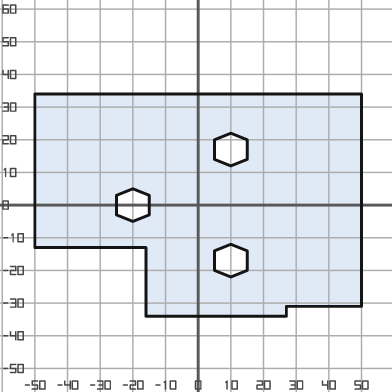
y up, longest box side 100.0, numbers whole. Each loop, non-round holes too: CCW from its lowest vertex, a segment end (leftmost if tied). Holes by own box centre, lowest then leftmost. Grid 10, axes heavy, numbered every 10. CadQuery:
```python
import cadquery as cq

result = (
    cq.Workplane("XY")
    .moveTo(-16.0, -34.0)
    .lineTo(27.0, -34.0)
    .lineTo(27.0, -31.0)
    .lineTo(50.0, -31.0)
    .lineTo(50.0, 34.0)
    .lineTo(-50.0, 34.0)
    .lineTo(-50.0, -13.0)
    .lineTo(-16.0, -13.0)
    .close()
    .moveTo(10.0, -22.0)
    .lineTo(15.0, -20.0)
    .lineTo(15.0, -14.0)
    .lineTo(10.0, -12.0)
    .lineTo(5.0, -14.0)
    .lineTo(5.0, -20.0)
    .close()
    .moveTo(-20.0, -5.0)
    .lineTo(-15.0, -3.0)
    .lineTo(-15.0, 3.0)
    .lineTo(-20.0, 5.0)
    .lineTo(-25.0, 3.0)
    .lineTo(-25.0, -3.0)
    .close()
    .moveTo(10.0, 12.0)
    .lineTo(15.0, 14.0)
    .lineTo(15.0, 20.0)
    .lineTo(10.0, 22.0)
    .lineTo(5.0, 20.0)
    .lineTo(5.0, 14.0)
    .close()
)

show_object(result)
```